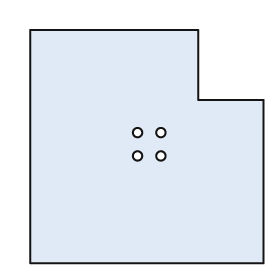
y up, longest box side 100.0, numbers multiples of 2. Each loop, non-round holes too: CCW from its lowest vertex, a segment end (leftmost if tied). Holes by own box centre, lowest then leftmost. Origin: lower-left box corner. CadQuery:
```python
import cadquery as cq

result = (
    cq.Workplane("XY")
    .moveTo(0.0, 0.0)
    .lineTo(100.0, 0.0)
    .lineTo(100.0, 70.0)
    .lineTo(72.0, 70.0)
    .lineTo(72.0, 100.0)
    .lineTo(0.0, 100.0)
    .close()
    .moveTo(46.0, 46.0)
    .circle(2.0)
    .moveTo(56.0, 46.0)
    .circle(2.0)
    .moveTo(46.0, 56.0)
    .circle(2.0)
    .moveTo(56.0, 56.0)
    .circle(2.0)
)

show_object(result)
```